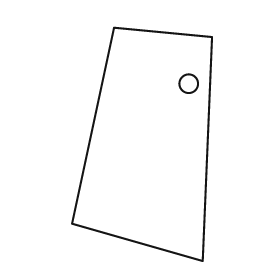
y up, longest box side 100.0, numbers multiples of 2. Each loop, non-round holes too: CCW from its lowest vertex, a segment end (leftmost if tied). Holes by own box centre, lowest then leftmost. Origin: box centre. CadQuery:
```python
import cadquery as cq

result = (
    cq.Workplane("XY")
    .moveTo(26.0, -50.0)
    .lineTo(30.0, 46.0)
    .lineTo(-12.0, 50.0)
    .lineTo(-30.0, -34.0)
    .close()
    .moveTo(20.0, 26.0)
    .circle(4.0)
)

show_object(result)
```